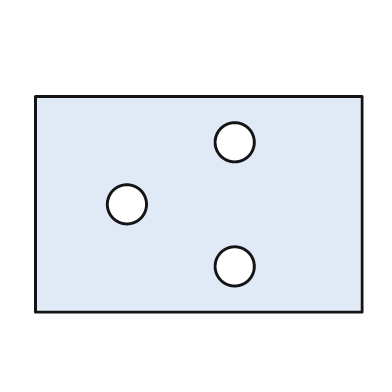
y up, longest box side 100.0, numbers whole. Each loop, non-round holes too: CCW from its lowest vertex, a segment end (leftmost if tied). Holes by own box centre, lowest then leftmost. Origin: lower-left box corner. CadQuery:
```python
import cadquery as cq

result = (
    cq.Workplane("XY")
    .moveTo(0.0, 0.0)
    .lineTo(100.0, 0.0)
    .lineTo(100.0, 66.0)
    .lineTo(0.0, 66.0)
    .close()
    .moveTo(61.0, 14.0)
    .circle(6.0)
    .moveTo(28.0, 33.0)
    .circle(6.0)
    .moveTo(61.0, 52.0)
    .circle(6.0)
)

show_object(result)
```